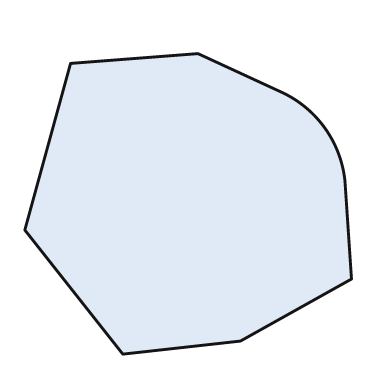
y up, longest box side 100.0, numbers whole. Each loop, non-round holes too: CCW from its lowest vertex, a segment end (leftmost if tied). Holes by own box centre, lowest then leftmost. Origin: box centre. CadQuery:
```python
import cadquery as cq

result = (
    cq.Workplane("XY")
    .moveTo(-20.0, -46.0)
    .lineTo(16.0, -42.0)
    .lineTo(50.0, -23.0)
    .lineTo(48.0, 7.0)
    .threePointArc((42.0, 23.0), (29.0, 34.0))
    .lineTo(3.0, 46.0)
    .lineTo(-36.0, 43.0)
    .lineTo(-50.0, -8.0)
    .close()
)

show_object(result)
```